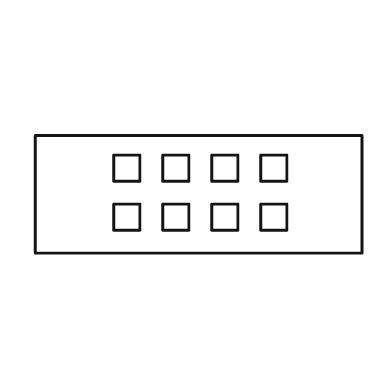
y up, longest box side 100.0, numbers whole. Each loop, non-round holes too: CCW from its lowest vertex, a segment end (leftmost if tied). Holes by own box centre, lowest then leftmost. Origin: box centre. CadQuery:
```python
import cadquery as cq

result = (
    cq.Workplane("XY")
    .moveTo(-50.0, -18.0)
    .lineTo(50.0, -18.0)
    .lineTo(50.0, 18.0)
    .lineTo(-50.0, 18.0)
    .close()
    .moveTo(-26.0, -11.0)
    .lineTo(-18.0, -11.0)
    .lineTo(-18.0, -3.0)
    .lineTo(-26.0, -3.0)
    .close()
    .moveTo(-11.0, -11.0)
    .lineTo(-3.0, -11.0)
    .lineTo(-3.0, -3.0)
    .lineTo(-11.0, -3.0)
    .close()
    .moveTo(4.0, -11.0)
    .lineTo(12.0, -11.0)
    .lineTo(12.0, -3.0)
    .lineTo(4.0, -3.0)
    .close()
    .moveTo(19.0, -11.0)
    .lineTo(27.0, -11.0)
    .lineTo(27.0, -3.0)
    .lineTo(19.0, -3.0)
    .close()
    .moveTo(-26.0, 4.0)
    .lineTo(-18.0, 4.0)
    .lineTo(-18.0, 12.0)
    .lineTo(-26.0, 12.0)
    .close()
    .moveTo(-11.0, 4.0)
    .lineTo(-3.0, 4.0)
    .lineTo(-3.0, 12.0)
    .lineTo(-11.0, 12.0)
    .close()
    .moveTo(4.0, 4.0)
    .lineTo(12.0, 4.0)
    .lineTo(12.0, 12.0)
    .lineTo(4.0, 12.0)
    .close()
    .moveTo(19.0, 4.0)
    .lineTo(27.0, 4.0)
    .lineTo(27.0, 12.0)
    .lineTo(19.0, 12.0)
    .close()
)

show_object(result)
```